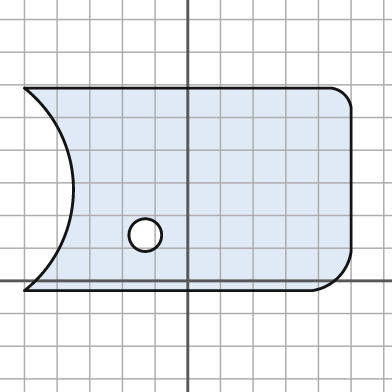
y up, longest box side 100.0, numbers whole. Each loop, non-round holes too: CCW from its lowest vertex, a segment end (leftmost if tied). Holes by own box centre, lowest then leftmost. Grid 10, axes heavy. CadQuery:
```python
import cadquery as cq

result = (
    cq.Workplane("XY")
    .moveTo(-50.0, -3.0)
    .lineTo(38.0, -3.0)
    .threePointArc((46.0, 1.0), (50.0, 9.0))
    .lineTo(50.0, 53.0)
    .threePointArc((48.0, 57.0), (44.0, 59.0))
    .lineTo(-50.0, 59.0)
    .threePointArc((-35.0, 28.0), (-50.0, -3.0))
    .close()
    .moveTo(-13.0, 14.0)
    .circle(5.0)
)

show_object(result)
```